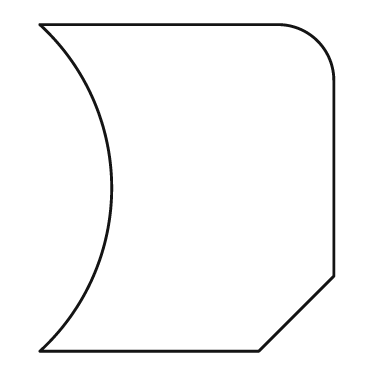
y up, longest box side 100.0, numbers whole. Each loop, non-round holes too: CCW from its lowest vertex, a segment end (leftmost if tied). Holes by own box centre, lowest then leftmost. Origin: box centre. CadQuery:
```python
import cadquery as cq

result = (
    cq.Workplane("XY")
    .moveTo(-45.0, -50.0)
    .lineTo(22.0, -50.0)
    .lineTo(45.0, -27.0)
    .lineTo(45.0, 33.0)
    .threePointArc((40.0, 45.0), (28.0, 50.0))
    .lineTo(-45.0, 50.0)
    .threePointArc((-23.0, 0.0), (-45.0, -50.0))
    .close()
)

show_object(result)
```